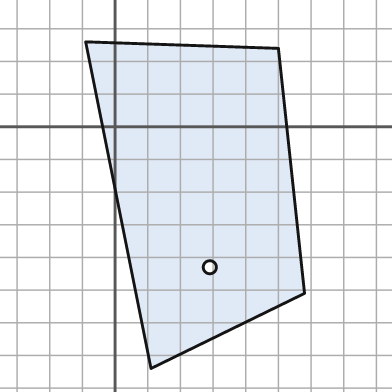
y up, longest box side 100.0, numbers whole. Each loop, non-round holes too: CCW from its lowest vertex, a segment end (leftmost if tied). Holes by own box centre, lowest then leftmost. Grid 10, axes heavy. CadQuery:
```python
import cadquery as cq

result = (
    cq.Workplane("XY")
    .moveTo(11.0, -74.0)
    .lineTo(58.0, -51.0)
    .lineTo(50.0, 24.0)
    .lineTo(-9.0, 26.0)
    .close()
    .moveTo(29.0, -43.0)
    .circle(2.0)
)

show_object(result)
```